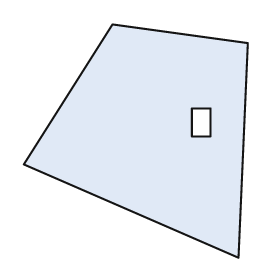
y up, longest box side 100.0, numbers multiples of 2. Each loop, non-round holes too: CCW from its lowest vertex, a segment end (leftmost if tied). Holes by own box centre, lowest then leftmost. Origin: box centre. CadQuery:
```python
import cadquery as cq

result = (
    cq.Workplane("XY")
    .moveTo(44.0, -50.0)
    .lineTo(48.0, 42.0)
    .lineTo(-10.0, 50.0)
    .lineTo(-48.0, -10.0)
    .close()
    .moveTo(24.0, 2.0)
    .lineTo(32.0, 2.0)
    .lineTo(32.0, 14.0)
    .lineTo(24.0, 14.0)
    .close()
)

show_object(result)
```